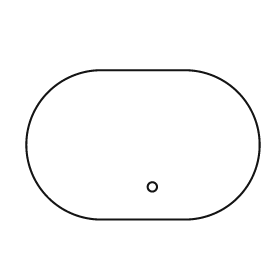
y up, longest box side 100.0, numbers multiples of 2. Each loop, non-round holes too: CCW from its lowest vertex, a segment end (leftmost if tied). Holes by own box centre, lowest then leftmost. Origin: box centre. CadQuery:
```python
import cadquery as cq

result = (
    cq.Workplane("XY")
    .moveTo(-18.0, -32.0)
    .lineTo(18.0, -32.0)
    .threePointArc((50.0, 0.0), (18.0, 32.0))
    .lineTo(-18.0, 32.0)
    .threePointArc((-50.0, 0.0), (-18.0, -32.0))
    .close()
    .moveTo(4.0, -18.0)
    .circle(2.0)
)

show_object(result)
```